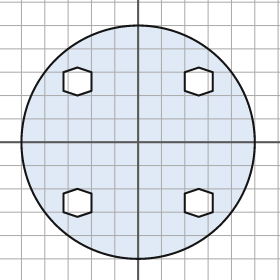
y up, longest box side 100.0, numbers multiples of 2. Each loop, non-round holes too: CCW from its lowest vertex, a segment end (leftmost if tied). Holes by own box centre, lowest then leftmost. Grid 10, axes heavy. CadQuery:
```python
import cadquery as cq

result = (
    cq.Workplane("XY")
    .moveTo(0.0, 0.0)
    .circle(50.0)
    .moveTo(-26.0, -32.0)
    .lineTo(-20.0, -30.0)
    .lineTo(-20.0, -22.0)
    .lineTo(-26.0, -20.0)
    .lineTo(-32.0, -22.0)
    .lineTo(-32.0, -30.0)
    .close()
    .moveTo(26.0, -32.0)
    .lineTo(32.0, -30.0)
    .lineTo(32.0, -22.0)
    .lineTo(26.0, -20.0)
    .lineTo(20.0, -22.0)
    .lineTo(20.0, -30.0)
    .close()
    .moveTo(-26.0, 20.0)
    .lineTo(-20.0, 22.0)
    .lineTo(-20.0, 30.0)
    .lineTo(-26.0, 32.0)
    .lineTo(-32.0, 30.0)
    .lineTo(-32.0, 22.0)
    .close()
    .moveTo(26.0, 20.0)
    .lineTo(32.0, 22.0)
    .lineTo(32.0, 30.0)
    .lineTo(26.0, 32.0)
    .lineTo(20.0, 30.0)
    .lineTo(20.0, 22.0)
    .close()
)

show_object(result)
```